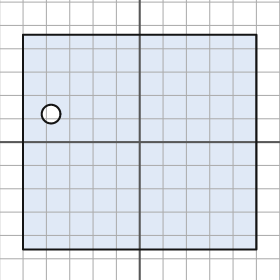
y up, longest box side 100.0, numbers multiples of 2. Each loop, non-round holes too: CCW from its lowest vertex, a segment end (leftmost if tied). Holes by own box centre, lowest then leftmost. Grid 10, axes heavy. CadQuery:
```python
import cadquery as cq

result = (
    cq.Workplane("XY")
    .moveTo(-50.0, -46.0)
    .lineTo(50.0, -46.0)
    .lineTo(50.0, 46.0)
    .lineTo(-50.0, 46.0)
    .close()
    .moveTo(-38.0, 12.0)
    .circle(4.0)
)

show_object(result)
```